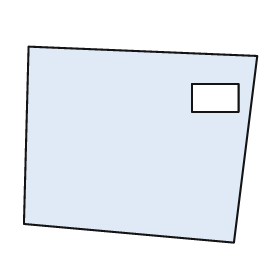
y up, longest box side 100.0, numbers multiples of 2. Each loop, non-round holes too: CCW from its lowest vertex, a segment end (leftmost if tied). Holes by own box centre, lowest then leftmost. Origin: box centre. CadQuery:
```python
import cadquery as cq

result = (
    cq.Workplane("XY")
    .moveTo(40.0, -42.0)
    .lineTo(50.0, 38.0)
    .lineTo(-48.0, 42.0)
    .lineTo(-50.0, -34.0)
    .close()
    .moveTo(22.0, 14.0)
    .lineTo(42.0, 14.0)
    .lineTo(42.0, 26.0)
    .lineTo(22.0, 26.0)
    .close()
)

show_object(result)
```